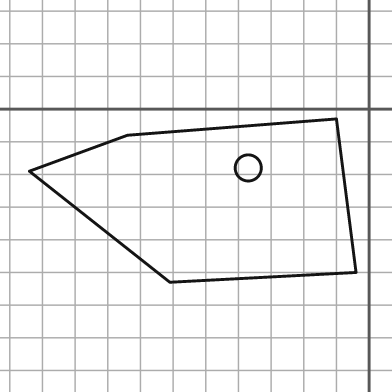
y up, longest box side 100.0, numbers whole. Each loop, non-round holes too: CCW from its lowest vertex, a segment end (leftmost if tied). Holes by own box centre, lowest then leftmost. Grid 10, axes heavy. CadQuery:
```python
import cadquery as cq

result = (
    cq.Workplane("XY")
    .moveTo(-61.0, -53.0)
    .lineTo(-4.0, -50.0)
    .lineTo(-10.0, -3.0)
    .lineTo(-74.0, -8.0)
    .lineTo(-104.0, -19.0)
    .close()
    .moveTo(-37.0, -18.0)
    .circle(4.0)
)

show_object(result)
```